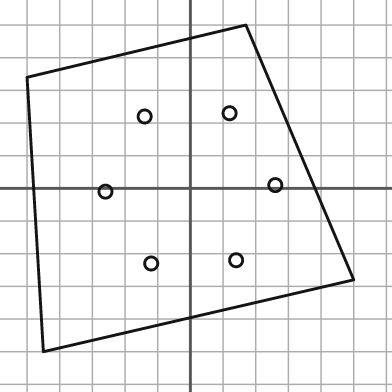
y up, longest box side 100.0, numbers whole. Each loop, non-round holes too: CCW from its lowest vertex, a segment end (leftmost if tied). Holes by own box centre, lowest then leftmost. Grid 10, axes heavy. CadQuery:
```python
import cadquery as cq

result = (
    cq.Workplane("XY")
    .moveTo(-45.0, -50.0)
    .lineTo(50.0, -28.0)
    .lineTo(17.0, 50.0)
    .lineTo(-50.0, 34.0)
    .close()
    .moveTo(-12.0, -23.0)
    .circle(2.0)
    .moveTo(14.0, -22.0)
    .circle(2.0)
    .moveTo(-26.0, -1.0)
    .circle(2.0)
    .moveTo(26.0, 1.0)
    .circle(2.0)
    .moveTo(-14.0, 22.0)
    .circle(2.0)
    .moveTo(12.0, 23.0)
    .circle(2.0)
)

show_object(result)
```